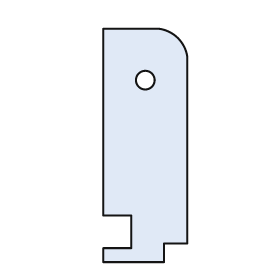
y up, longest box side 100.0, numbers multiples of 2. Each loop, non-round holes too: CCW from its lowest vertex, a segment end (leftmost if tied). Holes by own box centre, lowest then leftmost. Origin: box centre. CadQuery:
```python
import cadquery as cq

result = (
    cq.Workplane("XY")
    .moveTo(-18.0, -50.0)
    .lineTo(8.0, -50.0)
    .lineTo(8.0, -42.0)
    .lineTo(18.0, -42.0)
    .lineTo(18.0, 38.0)
    .threePointArc((14.0, 46.0), (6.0, 50.0))
    .lineTo(-18.0, 50.0)
    .lineTo(-18.0, -30.0)
    .lineTo(-6.0, -30.0)
    .lineTo(-6.0, -44.0)
    .lineTo(-18.0, -44.0)
    .close()
    .moveTo(0.0, 28.0)
    .circle(4.0)
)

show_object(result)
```